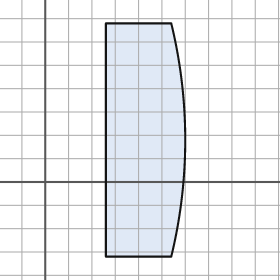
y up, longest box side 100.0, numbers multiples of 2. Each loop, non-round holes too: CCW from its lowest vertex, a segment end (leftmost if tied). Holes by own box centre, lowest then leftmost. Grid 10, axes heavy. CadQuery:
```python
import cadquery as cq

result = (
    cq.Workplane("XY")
    .moveTo(26.0, -32.0)
    .lineTo(54.0, -32.0)
    .threePointArc((60.0, 18.0), (54.0, 68.0))
    .lineTo(26.0, 68.0)
    .close()
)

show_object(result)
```